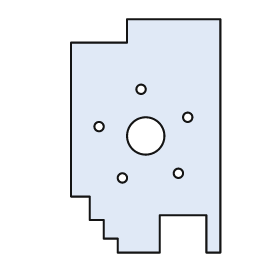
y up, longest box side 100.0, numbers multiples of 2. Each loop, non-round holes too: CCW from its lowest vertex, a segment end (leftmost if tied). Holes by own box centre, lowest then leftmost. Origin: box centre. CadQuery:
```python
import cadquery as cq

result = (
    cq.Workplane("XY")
    .moveTo(-12.0, -50.0)
    .lineTo(6.0, -50.0)
    .lineTo(6.0, -34.0)
    .lineTo(26.0, -34.0)
    .lineTo(26.0, -50.0)
    .lineTo(32.0, -50.0)
    .lineTo(32.0, 50.0)
    .lineTo(-8.0, 50.0)
    .lineTo(-8.0, 40.0)
    .lineTo(-32.0, 40.0)
    .lineTo(-32.0, -26.0)
    .lineTo(-24.0, -26.0)
    .lineTo(-24.0, -36.0)
    .lineTo(-18.0, -36.0)
    .lineTo(-18.0, -44.0)
    .lineTo(-12.0, -44.0)
    .close()
    .moveTo(-10.0, -18.0)
    .circle(2.0)
    .moveTo(14.0, -16.0)
    .circle(2.0)
    .moveTo(0.0, 0.0)
    .circle(8.0)
    .moveTo(-20.0, 4.0)
    .circle(2.0)
    .moveTo(18.0, 8.0)
    .circle(2.0)
    .moveTo(-2.0, 20.0)
    .circle(2.0)
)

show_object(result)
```